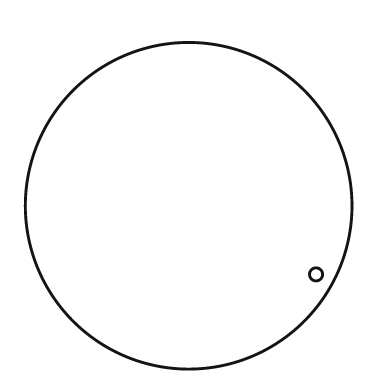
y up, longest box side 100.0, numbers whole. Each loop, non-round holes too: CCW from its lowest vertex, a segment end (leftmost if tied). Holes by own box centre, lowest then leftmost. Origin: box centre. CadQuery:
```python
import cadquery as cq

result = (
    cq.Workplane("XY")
    .moveTo(0.0, 0.0)
    .circle(50.0)
    .moveTo(39.0, -21.0)
    .circle(2.0)
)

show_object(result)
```